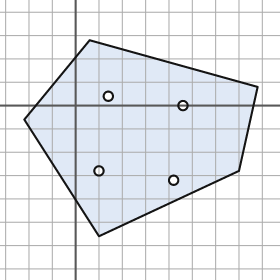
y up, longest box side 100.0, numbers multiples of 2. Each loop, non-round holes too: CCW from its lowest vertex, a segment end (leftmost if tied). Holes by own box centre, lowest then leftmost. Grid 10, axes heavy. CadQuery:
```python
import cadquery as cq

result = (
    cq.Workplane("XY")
    .moveTo(10.0, -56.0)
    .lineTo(70.0, -28.0)
    .lineTo(78.0, 8.0)
    .lineTo(6.0, 28.0)
    .lineTo(-22.0, -6.0)
    .close()
    .moveTo(42.0, -32.0)
    .circle(2.0)
    .moveTo(10.0, -28.0)
    .circle(2.0)
    .moveTo(46.0, 0.0)
    .circle(2.0)
    .moveTo(14.0, 4.0)
    .circle(2.0)
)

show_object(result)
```